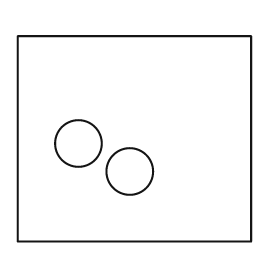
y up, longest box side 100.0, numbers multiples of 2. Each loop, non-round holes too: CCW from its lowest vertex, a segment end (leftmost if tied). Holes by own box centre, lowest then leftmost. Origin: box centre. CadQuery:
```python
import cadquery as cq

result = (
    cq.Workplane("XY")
    .moveTo(-50.0, -44.0)
    .lineTo(50.0, -44.0)
    .lineTo(50.0, 44.0)
    .lineTo(-50.0, 44.0)
    .close()
    .moveTo(-2.0, -14.0)
    .circle(10.0)
    .moveTo(-24.0, -2.0)
    .circle(10.0)
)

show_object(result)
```